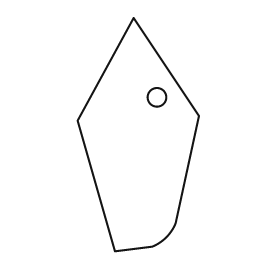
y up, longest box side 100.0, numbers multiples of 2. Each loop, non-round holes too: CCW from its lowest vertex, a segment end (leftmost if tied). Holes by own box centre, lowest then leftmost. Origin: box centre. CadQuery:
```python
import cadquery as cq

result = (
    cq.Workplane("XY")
    .moveTo(-10.0, -50.0)
    .lineTo(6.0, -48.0)
    .threePointArc((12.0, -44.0), (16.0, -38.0))
    .lineTo(26.0, 8.0)
    .lineTo(-2.0, 50.0)
    .lineTo(-26.0, 6.0)
    .close()
    .moveTo(8.0, 16.0)
    .circle(4.0)
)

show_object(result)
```